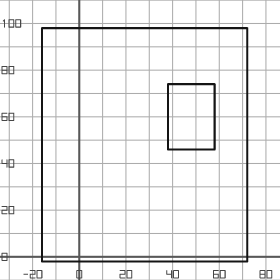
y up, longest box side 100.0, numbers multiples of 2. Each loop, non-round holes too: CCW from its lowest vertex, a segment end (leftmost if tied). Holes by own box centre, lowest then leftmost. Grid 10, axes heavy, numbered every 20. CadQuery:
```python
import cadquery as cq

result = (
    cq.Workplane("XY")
    .moveTo(-16.0, -2.0)
    .lineTo(72.0, -2.0)
    .lineTo(72.0, 98.0)
    .lineTo(-16.0, 98.0)
    .close()
    .moveTo(38.0, 46.0)
    .lineTo(58.0, 46.0)
    .lineTo(58.0, 74.0)
    .lineTo(38.0, 74.0)
    .close()
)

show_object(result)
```